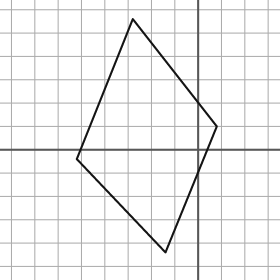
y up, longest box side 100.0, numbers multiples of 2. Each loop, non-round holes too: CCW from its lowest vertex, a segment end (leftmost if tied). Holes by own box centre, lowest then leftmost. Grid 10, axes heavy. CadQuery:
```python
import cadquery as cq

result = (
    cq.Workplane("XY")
    .moveTo(-14.0, -44.0)
    .lineTo(8.0, 10.0)
    .lineTo(-28.0, 56.0)
    .lineTo(-52.0, -4.0)
    .close()
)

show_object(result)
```